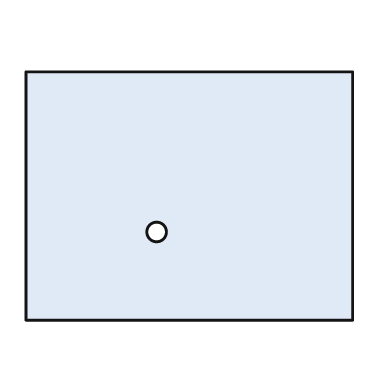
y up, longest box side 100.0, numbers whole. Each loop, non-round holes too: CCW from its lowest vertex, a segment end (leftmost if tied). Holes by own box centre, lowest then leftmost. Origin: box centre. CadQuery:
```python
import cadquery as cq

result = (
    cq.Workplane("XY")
    .moveTo(-50.0, -38.0)
    .lineTo(50.0, -38.0)
    .lineTo(50.0, 38.0)
    .lineTo(-50.0, 38.0)
    .close()
    .moveTo(-10.0, -11.0)
    .circle(3.0)
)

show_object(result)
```